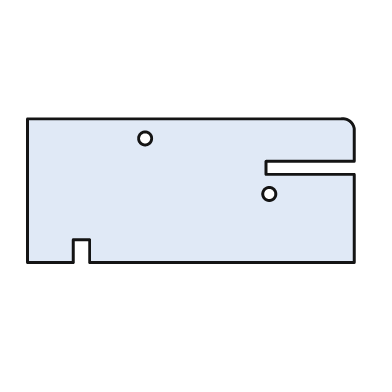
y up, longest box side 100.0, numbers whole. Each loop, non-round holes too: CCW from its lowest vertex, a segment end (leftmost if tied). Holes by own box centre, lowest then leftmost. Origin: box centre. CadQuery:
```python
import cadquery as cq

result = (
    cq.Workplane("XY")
    .moveTo(-50.0, -22.0)
    .lineTo(-36.0, -22.0)
    .lineTo(-36.0, -15.0)
    .lineTo(-31.0, -15.0)
    .lineTo(-31.0, -22.0)
    .lineTo(50.0, -22.0)
    .lineTo(50.0, 5.0)
    .lineTo(23.0, 5.0)
    .lineTo(23.0, 9.0)
    .lineTo(50.0, 9.0)
    .lineTo(50.0, 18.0)
    .threePointArc((49.0, 21.0), (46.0, 22.0))
    .lineTo(-50.0, 22.0)
    .close()
    .moveTo(24.0, -1.0)
    .circle(2.0)
    .moveTo(-14.0, 16.0)
    .circle(2.0)
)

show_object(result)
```